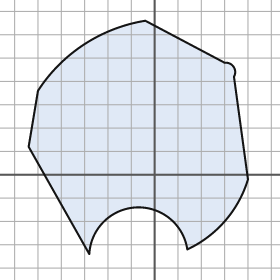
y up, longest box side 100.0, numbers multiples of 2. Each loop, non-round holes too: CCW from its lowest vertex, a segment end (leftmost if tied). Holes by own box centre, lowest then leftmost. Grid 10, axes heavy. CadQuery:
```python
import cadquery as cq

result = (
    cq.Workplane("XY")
    .moveTo(-28.0, -34.0)
    .threePointArc((-8.0, -14.0), (14.0, -32.0))
    .threePointArc((30.0, -20.0), (40.0, -2.0))
    .lineTo(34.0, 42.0)
    .threePointArc((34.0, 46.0), (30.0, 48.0))
    .lineTo(-4.0, 66.0)
    .threePointArc((-30.0, 56.0), (-50.0, 36.0))
    .lineTo(-54.0, 12.0)
    .close()
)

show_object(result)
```